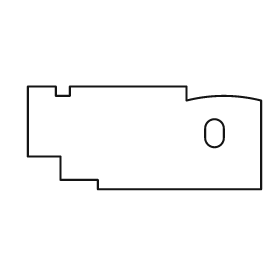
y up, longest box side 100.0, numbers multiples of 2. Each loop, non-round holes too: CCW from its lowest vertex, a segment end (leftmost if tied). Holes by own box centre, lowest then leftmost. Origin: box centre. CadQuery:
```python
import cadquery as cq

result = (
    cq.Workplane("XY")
    .moveTo(-20.0, -22.0)
    .lineTo(50.0, -22.0)
    .lineTo(50.0, 16.0)
    .threePointArc((34.0, 18.0), (18.0, 16.0))
    .lineTo(18.0, 22.0)
    .lineTo(-32.0, 22.0)
    .lineTo(-32.0, 18.0)
    .lineTo(-38.0, 18.0)
    .lineTo(-38.0, 22.0)
    .lineTo(-50.0, 22.0)
    .lineTo(-50.0, -8.0)
    .lineTo(-36.0, -8.0)
    .lineTo(-36.0, -18.0)
    .lineTo(-20.0, -18.0)
    .close()
    .moveTo(26.0, 0.0)
    .threePointArc((30.0, -4.0), (34.0, 0.0))
    .lineTo(34.0, 4.0)
    .threePointArc((30.0, 8.0), (26.0, 4.0))
    .close()
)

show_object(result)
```